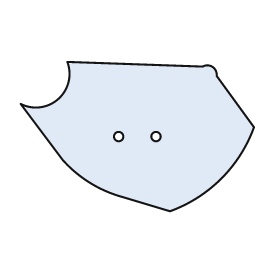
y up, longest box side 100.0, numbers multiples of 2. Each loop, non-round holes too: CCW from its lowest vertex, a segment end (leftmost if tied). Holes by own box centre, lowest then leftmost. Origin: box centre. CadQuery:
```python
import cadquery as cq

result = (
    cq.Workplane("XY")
    .moveTo(14.0, -32.0)
    .threePointArc((36.0, -18.0), (50.0, 4.0))
    .lineTo(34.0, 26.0)
    .threePointArc((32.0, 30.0), (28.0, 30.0))
    .lineTo(-30.0, 32.0)
    .threePointArc((-34.0, 16.0), (-50.0, 14.0))
    .lineTo(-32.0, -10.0)
    .threePointArc((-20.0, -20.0), (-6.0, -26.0))
    .close()
    .moveTo(-8.0, 0.0)
    .circle(2.0)
    .moveTo(8.0, 0.0)
    .circle(2.0)
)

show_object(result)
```